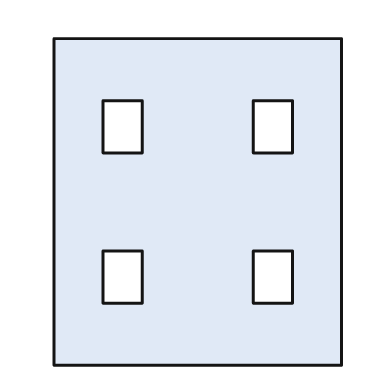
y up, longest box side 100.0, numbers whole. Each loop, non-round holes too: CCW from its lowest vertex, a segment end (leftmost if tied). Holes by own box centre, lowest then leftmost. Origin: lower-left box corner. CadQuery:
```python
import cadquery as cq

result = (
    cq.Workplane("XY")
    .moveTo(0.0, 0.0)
    .lineTo(88.0, 0.0)
    .lineTo(88.0, 100.0)
    .lineTo(0.0, 100.0)
    .close()
    .moveTo(15.0, 19.0)
    .lineTo(27.0, 19.0)
    .lineTo(27.0, 35.0)
    .lineTo(15.0, 35.0)
    .close()
    .moveTo(61.0, 19.0)
    .lineTo(73.0, 19.0)
    .lineTo(73.0, 35.0)
    .lineTo(61.0, 35.0)
    .close()
    .moveTo(15.0, 65.0)
    .lineTo(27.0, 65.0)
    .lineTo(27.0, 81.0)
    .lineTo(15.0, 81.0)
    .close()
    .moveTo(61.0, 65.0)
    .lineTo(73.0, 65.0)
    .lineTo(73.0, 81.0)
    .lineTo(61.0, 81.0)
    .close()
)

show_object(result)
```